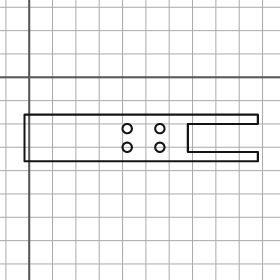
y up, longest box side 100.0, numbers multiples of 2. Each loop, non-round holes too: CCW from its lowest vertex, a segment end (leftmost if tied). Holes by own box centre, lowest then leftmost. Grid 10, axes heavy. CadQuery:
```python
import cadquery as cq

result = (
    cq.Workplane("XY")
    .moveTo(-2.0, -36.0)
    .lineTo(98.0, -36.0)
    .lineTo(98.0, -32.0)
    .lineTo(68.0, -32.0)
    .lineTo(68.0, -20.0)
    .lineTo(98.0, -20.0)
    .lineTo(98.0, -16.0)
    .lineTo(-2.0, -16.0)
    .close()
    .moveTo(42.0, -30.0)
    .circle(2.0)
    .moveTo(56.0, -30.0)
    .circle(2.0)
    .moveTo(42.0, -22.0)
    .circle(2.0)
    .moveTo(56.0, -22.0)
    .circle(2.0)
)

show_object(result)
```